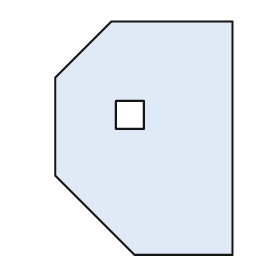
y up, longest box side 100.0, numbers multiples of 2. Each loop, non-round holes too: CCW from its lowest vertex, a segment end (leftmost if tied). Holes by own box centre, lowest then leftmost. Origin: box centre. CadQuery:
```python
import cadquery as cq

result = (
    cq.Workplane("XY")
    .moveTo(-4.0, -50.0)
    .lineTo(38.0, -50.0)
    .lineTo(38.0, 50.0)
    .lineTo(-14.0, 50.0)
    .lineTo(-38.0, 26.0)
    .lineTo(-38.0, -16.0)
    .close()
    .moveTo(-12.0, 4.0)
    .lineTo(0.0, 4.0)
    .lineTo(0.0, 16.0)
    .lineTo(-12.0, 16.0)
    .close()
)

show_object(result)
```